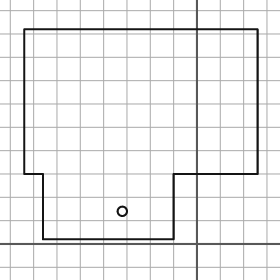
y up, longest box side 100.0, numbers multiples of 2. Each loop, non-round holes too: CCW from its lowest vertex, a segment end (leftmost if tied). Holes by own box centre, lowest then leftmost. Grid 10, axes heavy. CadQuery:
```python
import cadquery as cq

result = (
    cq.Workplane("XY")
    .moveTo(-66.0, 2.0)
    .lineTo(-10.0, 2.0)
    .lineTo(-10.0, 30.0)
    .lineTo(26.0, 30.0)
    .lineTo(26.0, 92.0)
    .lineTo(-74.0, 92.0)
    .lineTo(-74.0, 30.0)
    .lineTo(-66.0, 30.0)
    .close()
    .moveTo(-32.0, 14.0)
    .circle(2.0)
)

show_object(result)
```